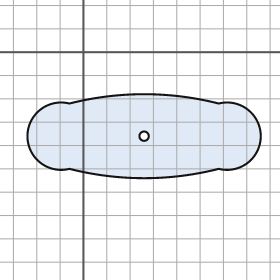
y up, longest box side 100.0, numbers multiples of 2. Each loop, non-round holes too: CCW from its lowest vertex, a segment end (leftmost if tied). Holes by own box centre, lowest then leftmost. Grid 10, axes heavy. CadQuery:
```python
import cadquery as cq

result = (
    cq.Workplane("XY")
    .moveTo(-6.0, -50.0)
    .threePointArc((26.0, -54.0), (58.0, -50.0))
    .threePointArc((76.0, -36.0), (58.0, -22.0))
    .threePointArc((26.0, -18.0), (-6.0, -22.0))
    .threePointArc((-24.0, -36.0), (-6.0, -50.0))
    .close()
    .moveTo(26.0, -36.0)
    .circle(2.0)
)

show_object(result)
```